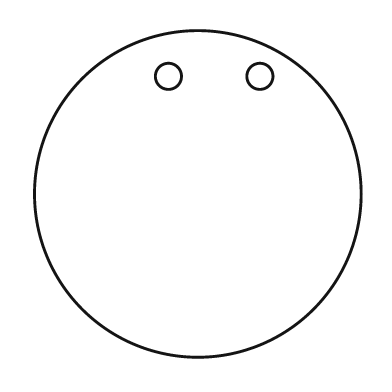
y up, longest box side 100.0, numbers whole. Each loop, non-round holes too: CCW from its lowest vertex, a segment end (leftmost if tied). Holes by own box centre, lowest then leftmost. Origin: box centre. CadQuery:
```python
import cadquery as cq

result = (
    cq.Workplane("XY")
    .moveTo(0.0, 0.0)
    .circle(50.0)
    .moveTo(-9.0, 36.0)
    .circle(4.0)
    .moveTo(19.0, 36.0)
    .circle(4.0)
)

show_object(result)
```